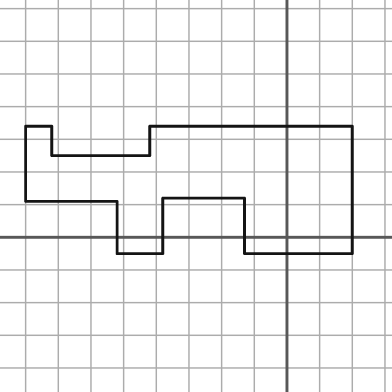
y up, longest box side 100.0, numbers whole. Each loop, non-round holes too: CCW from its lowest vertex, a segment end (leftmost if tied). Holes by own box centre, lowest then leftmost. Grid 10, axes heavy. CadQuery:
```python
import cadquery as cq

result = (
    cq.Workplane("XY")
    .moveTo(-52.0, -5.0)
    .lineTo(-38.0, -5.0)
    .lineTo(-38.0, 12.0)
    .lineTo(-13.0, 12.0)
    .lineTo(-13.0, -5.0)
    .lineTo(20.0, -5.0)
    .lineTo(20.0, 34.0)
    .lineTo(-42.0, 34.0)
    .lineTo(-42.0, 25.0)
    .lineTo(-72.0, 25.0)
    .lineTo(-72.0, 34.0)
    .lineTo(-80.0, 34.0)
    .lineTo(-80.0, 11.0)
    .lineTo(-52.0, 11.0)
    .close()
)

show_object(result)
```